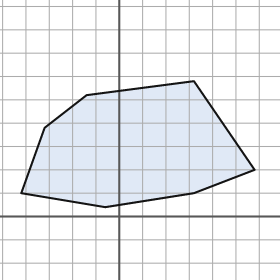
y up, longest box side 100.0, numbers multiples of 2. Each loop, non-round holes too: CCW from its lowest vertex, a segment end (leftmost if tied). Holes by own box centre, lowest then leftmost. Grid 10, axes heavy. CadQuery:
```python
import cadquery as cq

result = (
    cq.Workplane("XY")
    .moveTo(-6.0, 4.0)
    .lineTo(32.0, 10.0)
    .lineTo(58.0, 20.0)
    .lineTo(32.0, 58.0)
    .lineTo(-14.0, 52.0)
    .lineTo(-32.0, 38.0)
    .lineTo(-42.0, 10.0)
    .close()
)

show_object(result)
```